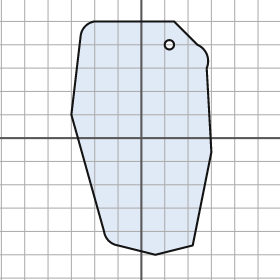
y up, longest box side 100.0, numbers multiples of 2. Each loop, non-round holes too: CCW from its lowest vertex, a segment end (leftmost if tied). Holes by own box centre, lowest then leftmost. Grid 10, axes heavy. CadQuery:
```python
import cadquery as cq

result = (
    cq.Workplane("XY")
    .moveTo(6.0, -50.0)
    .lineTo(22.0, -46.0)
    .lineTo(30.0, -6.0)
    .lineTo(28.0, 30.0)
    .threePointArc((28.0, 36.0), (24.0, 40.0))
    .lineTo(14.0, 50.0)
    .lineTo(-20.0, 50.0)
    .threePointArc((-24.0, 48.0), (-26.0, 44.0))
    .lineTo(-30.0, 10.0)
    .lineTo(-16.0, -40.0)
    .threePointArc((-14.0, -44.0), (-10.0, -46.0))
    .close()
    .moveTo(12.0, 40.0)
    .circle(2.0)
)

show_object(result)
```